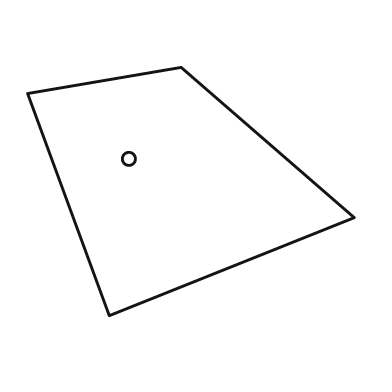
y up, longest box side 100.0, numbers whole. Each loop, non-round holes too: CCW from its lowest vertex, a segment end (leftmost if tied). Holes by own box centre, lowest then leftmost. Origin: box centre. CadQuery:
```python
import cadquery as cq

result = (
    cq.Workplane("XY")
    .moveTo(-25.0, -38.0)
    .lineTo(50.0, -8.0)
    .lineTo(-3.0, 38.0)
    .lineTo(-50.0, 30.0)
    .close()
    .moveTo(-19.0, 10.0)
    .circle(2.0)
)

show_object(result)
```